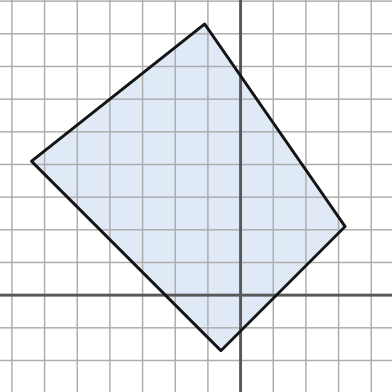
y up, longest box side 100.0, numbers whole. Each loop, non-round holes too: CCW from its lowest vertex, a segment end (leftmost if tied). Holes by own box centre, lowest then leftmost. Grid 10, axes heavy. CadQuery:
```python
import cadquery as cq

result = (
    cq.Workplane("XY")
    .moveTo(-6.0, -17.0)
    .lineTo(32.0, 21.0)
    .lineTo(-11.0, 83.0)
    .lineTo(-64.0, 41.0)
    .close()
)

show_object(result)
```